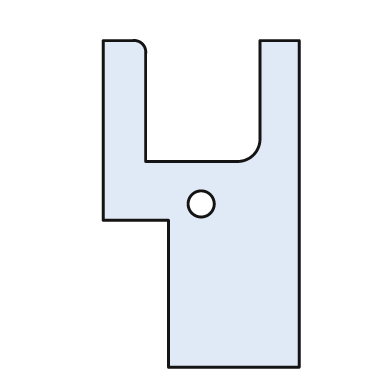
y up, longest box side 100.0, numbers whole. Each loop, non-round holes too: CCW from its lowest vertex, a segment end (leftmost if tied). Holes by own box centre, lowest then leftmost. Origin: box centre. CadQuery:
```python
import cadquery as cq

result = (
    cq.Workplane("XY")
    .moveTo(-10.0, -50.0)
    .lineTo(30.0, -50.0)
    .lineTo(30.0, 50.0)
    .lineTo(18.0, 50.0)
    .lineTo(18.0, 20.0)
    .threePointArc((16.0, 15.0), (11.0, 13.0))
    .lineTo(-17.0, 13.0)
    .lineTo(-17.0, 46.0)
    .threePointArc((-18.0, 49.0), (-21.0, 50.0))
    .lineTo(-30.0, 50.0)
    .lineTo(-30.0, -5.0)
    .lineTo(-10.0, -5.0)
    .close()
    .moveTo(0.0, 0.0)
    .circle(4.0)
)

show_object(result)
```